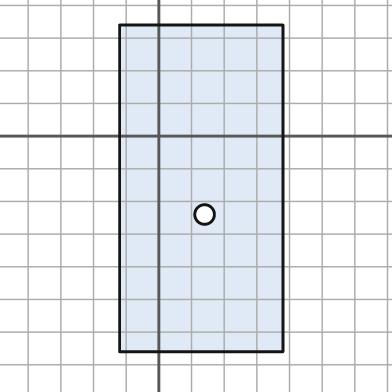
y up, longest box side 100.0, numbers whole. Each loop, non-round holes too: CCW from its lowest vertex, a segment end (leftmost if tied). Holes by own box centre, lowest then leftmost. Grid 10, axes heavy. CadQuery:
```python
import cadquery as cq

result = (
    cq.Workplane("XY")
    .moveTo(-12.0, -66.0)
    .lineTo(38.0, -66.0)
    .lineTo(38.0, 34.0)
    .lineTo(-12.0, 34.0)
    .close()
    .moveTo(14.0, -24.0)
    .circle(3.0)
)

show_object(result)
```